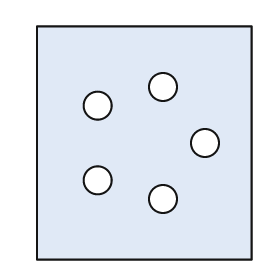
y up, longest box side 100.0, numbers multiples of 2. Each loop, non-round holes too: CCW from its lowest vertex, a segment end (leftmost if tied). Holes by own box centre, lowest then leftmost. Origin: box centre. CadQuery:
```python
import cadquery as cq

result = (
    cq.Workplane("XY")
    .moveTo(-46.0, -50.0)
    .lineTo(46.0, -50.0)
    .lineTo(46.0, 50.0)
    .lineTo(-46.0, 50.0)
    .close()
    .moveTo(8.0, -24.0)
    .circle(6.0)
    .moveTo(-20.0, -16.0)
    .circle(6.0)
    .moveTo(26.0, 0.0)
    .circle(6.0)
    .moveTo(-20.0, 16.0)
    .circle(6.0)
    .moveTo(8.0, 24.0)
    .circle(6.0)
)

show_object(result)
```